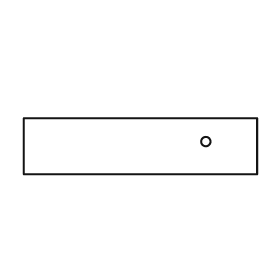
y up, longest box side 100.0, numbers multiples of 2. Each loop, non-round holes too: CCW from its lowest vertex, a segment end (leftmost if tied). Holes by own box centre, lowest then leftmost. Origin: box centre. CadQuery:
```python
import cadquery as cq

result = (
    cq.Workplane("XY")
    .moveTo(-50.0, -12.0)
    .lineTo(50.0, -12.0)
    .lineTo(50.0, 12.0)
    .lineTo(-50.0, 12.0)
    .close()
    .moveTo(28.0, 2.0)
    .circle(2.0)
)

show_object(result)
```